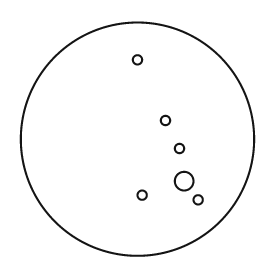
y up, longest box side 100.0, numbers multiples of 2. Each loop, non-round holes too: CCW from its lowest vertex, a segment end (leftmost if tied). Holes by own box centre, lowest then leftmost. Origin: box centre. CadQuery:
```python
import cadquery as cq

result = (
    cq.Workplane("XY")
    .moveTo(0.0, 0.0)
    .circle(50.0)
    .moveTo(26.0, -26.0)
    .circle(2.0)
    .moveTo(2.0, -24.0)
    .circle(2.0)
    .moveTo(20.0, -18.0)
    .circle(4.0)
    .moveTo(18.0, -4.0)
    .circle(2.0)
    .moveTo(12.0, 8.0)
    .circle(2.0)
    .moveTo(0.0, 34.0)
    .circle(2.0)
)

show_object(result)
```